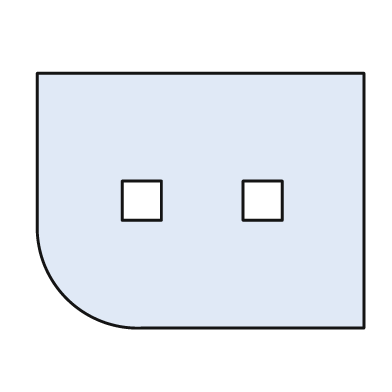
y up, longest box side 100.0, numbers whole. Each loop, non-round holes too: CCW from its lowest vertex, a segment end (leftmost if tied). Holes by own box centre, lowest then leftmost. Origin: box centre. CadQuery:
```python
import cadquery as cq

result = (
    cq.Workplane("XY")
    .moveTo(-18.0, -39.0)
    .lineTo(50.0, -39.0)
    .lineTo(50.0, 39.0)
    .lineTo(-50.0, 39.0)
    .lineTo(-50.0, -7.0)
    .threePointArc((-41.0, -30.0), (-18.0, -39.0))
    .close()
    .moveTo(-24.0, -6.0)
    .lineTo(-12.0, -6.0)
    .lineTo(-12.0, 6.0)
    .lineTo(-24.0, 6.0)
    .close()
    .moveTo(13.0, -6.0)
    .lineTo(25.0, -6.0)
    .lineTo(25.0, 6.0)
    .lineTo(13.0, 6.0)
    .close()
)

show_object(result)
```